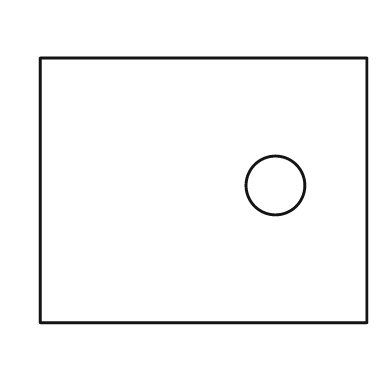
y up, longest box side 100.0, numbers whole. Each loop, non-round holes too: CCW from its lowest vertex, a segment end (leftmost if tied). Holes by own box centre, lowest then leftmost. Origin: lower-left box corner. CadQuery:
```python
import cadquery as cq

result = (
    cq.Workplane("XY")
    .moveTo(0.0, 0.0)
    .lineTo(100.0, 0.0)
    .lineTo(100.0, 81.0)
    .lineTo(0.0, 81.0)
    .close()
    .moveTo(72.0, 42.0)
    .circle(9.0)
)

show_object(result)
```